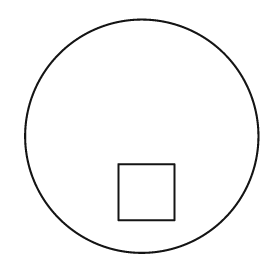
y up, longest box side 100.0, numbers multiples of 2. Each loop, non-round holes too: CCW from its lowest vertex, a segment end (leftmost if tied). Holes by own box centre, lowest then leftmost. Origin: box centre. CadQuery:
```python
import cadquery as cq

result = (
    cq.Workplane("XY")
    .moveTo(0.0, 0.0)
    .circle(50.0)
    .moveTo(-10.0, -36.0)
    .lineTo(14.0, -36.0)
    .lineTo(14.0, -12.0)
    .lineTo(-10.0, -12.0)
    .close()
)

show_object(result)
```